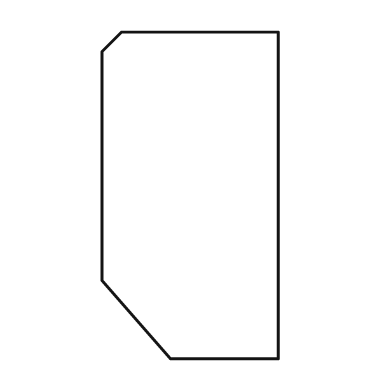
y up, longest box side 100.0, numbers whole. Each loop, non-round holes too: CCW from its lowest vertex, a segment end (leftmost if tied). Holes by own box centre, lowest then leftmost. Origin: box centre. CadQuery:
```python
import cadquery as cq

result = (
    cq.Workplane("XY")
    .moveTo(-6.0, -50.0)
    .lineTo(27.0, -50.0)
    .lineTo(27.0, 50.0)
    .lineTo(-21.0, 50.0)
    .lineTo(-27.0, 44.0)
    .lineTo(-27.0, -26.0)
    .close()
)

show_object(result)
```